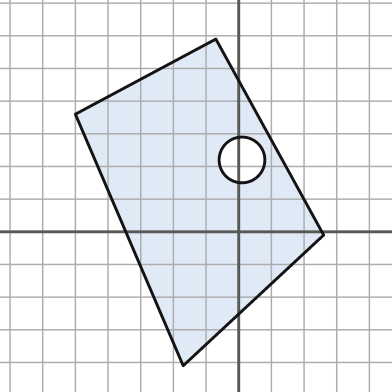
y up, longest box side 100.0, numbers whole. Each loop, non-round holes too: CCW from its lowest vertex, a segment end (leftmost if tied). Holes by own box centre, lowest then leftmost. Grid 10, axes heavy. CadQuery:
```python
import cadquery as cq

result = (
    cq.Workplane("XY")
    .moveTo(-17.0, -41.0)
    .lineTo(26.0, -1.0)
    .lineTo(-7.0, 59.0)
    .lineTo(-50.0, 36.0)
    .close()
    .moveTo(1.0, 22.0)
    .circle(7.0)
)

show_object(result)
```